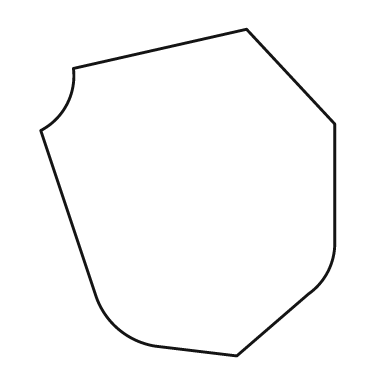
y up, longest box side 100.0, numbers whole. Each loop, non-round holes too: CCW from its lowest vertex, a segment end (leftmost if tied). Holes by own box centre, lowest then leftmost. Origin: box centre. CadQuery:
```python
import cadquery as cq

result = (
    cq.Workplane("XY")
    .moveTo(15.0, -50.0)
    .lineTo(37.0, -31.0)
    .threePointArc((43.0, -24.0), (45.0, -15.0))
    .lineTo(45.0, 21.0)
    .lineTo(18.0, 50.0)
    .lineTo(-35.0, 38.0)
    .threePointArc((-37.0, 27.0), (-45.0, 19.0))
    .lineTo(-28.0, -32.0)
    .threePointArc((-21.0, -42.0), (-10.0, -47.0))
    .close()
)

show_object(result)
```